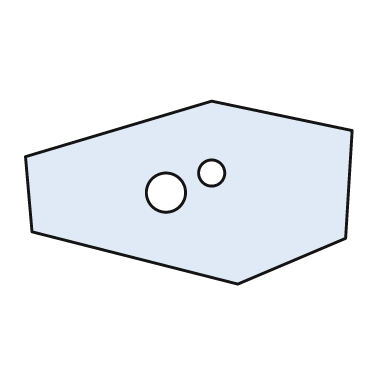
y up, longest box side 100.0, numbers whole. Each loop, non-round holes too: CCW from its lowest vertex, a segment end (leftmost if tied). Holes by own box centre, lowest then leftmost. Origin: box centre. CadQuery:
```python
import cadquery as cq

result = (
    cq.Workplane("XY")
    .moveTo(15.0, -28.0)
    .lineTo(48.0, -14.0)
    .lineTo(50.0, 19.0)
    .lineTo(7.0, 28.0)
    .lineTo(-50.0, 11.0)
    .lineTo(-48.0, -12.0)
    .close()
    .moveTo(-7.0, 0.0)
    .circle(6.0)
    .moveTo(7.0, 6.0)
    .circle(4.0)
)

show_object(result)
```